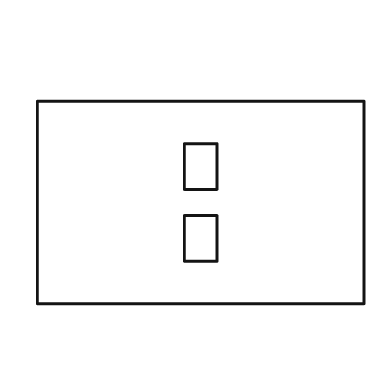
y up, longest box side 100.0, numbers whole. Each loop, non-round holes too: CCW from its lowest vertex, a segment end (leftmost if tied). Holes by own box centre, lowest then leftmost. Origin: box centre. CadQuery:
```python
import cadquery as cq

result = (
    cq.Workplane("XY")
    .moveTo(-50.0, -31.0)
    .lineTo(50.0, -31.0)
    .lineTo(50.0, 31.0)
    .lineTo(-50.0, 31.0)
    .close()
    .moveTo(-5.0, -18.0)
    .lineTo(5.0, -18.0)
    .lineTo(5.0, -4.0)
    .lineTo(-5.0, -4.0)
    .close()
    .moveTo(-5.0, 4.0)
    .lineTo(5.0, 4.0)
    .lineTo(5.0, 18.0)
    .lineTo(-5.0, 18.0)
    .close()
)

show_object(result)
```